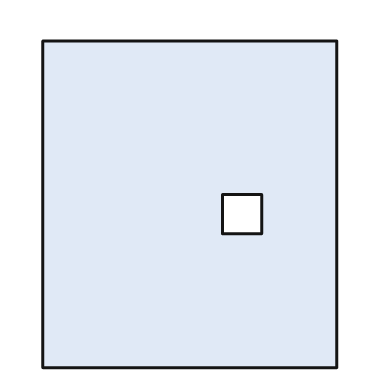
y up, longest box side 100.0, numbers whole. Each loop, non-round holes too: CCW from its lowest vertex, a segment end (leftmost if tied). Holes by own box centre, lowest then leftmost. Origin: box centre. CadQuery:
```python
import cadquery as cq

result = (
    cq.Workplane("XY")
    .moveTo(-45.0, -50.0)
    .lineTo(45.0, -50.0)
    .lineTo(45.0, 50.0)
    .lineTo(-45.0, 50.0)
    .close()
    .moveTo(10.0, -9.0)
    .lineTo(22.0, -9.0)
    .lineTo(22.0, 3.0)
    .lineTo(10.0, 3.0)
    .close()
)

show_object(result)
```